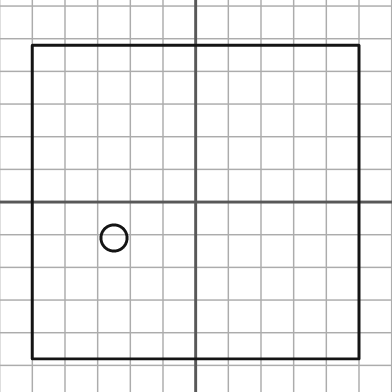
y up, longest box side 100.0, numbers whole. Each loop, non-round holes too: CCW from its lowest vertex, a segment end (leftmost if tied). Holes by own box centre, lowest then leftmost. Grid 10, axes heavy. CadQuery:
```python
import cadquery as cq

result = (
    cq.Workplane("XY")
    .moveTo(-50.0, -48.0)
    .lineTo(50.0, -48.0)
    .lineTo(50.0, 48.0)
    .lineTo(-50.0, 48.0)
    .close()
    .moveTo(-25.0, -11.0)
    .circle(4.0)
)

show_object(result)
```